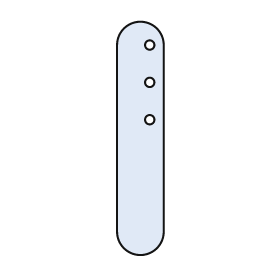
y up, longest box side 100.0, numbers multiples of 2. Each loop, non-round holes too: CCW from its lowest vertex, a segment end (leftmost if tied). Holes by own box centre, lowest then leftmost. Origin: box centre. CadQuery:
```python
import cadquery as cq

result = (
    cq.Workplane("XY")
    .moveTo(-10.0, -40.0)
    .threePointArc((0.0, -50.0), (10.0, -40.0))
    .lineTo(10.0, 40.0)
    .threePointArc((0.0, 50.0), (-10.0, 40.0))
    .close()
    .moveTo(4.0, 8.0)
    .circle(2.0)
    .moveTo(4.0, 24.0)
    .circle(2.0)
    .moveTo(4.0, 40.0)
    .circle(2.0)
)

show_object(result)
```